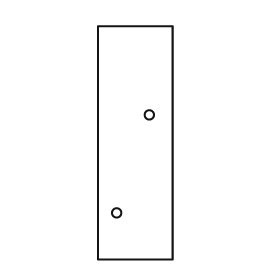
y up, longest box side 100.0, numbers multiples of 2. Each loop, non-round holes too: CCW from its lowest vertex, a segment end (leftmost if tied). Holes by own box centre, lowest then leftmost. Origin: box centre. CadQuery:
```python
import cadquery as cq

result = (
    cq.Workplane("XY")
    .moveTo(-16.0, -50.0)
    .lineTo(16.0, -50.0)
    .lineTo(16.0, 50.0)
    .lineTo(-16.0, 50.0)
    .close()
    .moveTo(-8.0, -30.0)
    .circle(2.0)
    .moveTo(6.0, 12.0)
    .circle(2.0)
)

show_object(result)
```